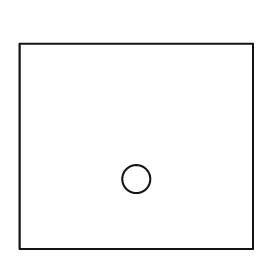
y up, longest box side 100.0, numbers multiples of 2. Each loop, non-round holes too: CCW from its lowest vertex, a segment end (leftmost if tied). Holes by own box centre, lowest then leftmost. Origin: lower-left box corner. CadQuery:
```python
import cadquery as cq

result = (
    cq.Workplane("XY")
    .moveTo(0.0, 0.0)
    .lineTo(100.0, 0.0)
    .lineTo(100.0, 88.0)
    .lineTo(0.0, 88.0)
    .close()
    .moveTo(50.0, 30.0)
    .circle(6.0)
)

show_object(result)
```